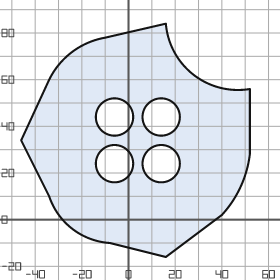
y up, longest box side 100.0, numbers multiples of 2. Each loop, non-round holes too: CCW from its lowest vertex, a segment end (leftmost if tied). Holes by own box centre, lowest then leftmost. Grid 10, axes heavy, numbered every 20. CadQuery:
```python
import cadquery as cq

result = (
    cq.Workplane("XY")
    .moveTo(16.0, -16.0)
    .lineTo(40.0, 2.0)
    .threePointArc((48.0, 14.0), (52.0, 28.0))
    .lineTo(52.0, 56.0)
    .threePointArc((28.0, 62.0), (16.0, 84.0))
    .lineTo(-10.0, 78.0)
    .threePointArc((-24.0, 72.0), (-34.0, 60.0))
    .lineTo(-46.0, 34.0)
    .lineTo(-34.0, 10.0)
    .threePointArc((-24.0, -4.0), (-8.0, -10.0))
    .close()
    .moveTo(-6.0, 24.0)
    .circle(8.0)
    .moveTo(14.0, 24.0)
    .circle(8.0)
    .moveTo(-6.0, 44.0)
    .circle(8.0)
    .moveTo(14.0, 44.0)
    .circle(8.0)
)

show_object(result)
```